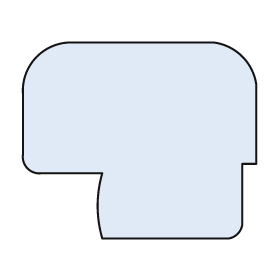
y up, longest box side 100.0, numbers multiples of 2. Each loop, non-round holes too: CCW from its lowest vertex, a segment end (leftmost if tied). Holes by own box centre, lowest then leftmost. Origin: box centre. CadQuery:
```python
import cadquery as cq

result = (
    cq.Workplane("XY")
    .moveTo(-16.0, -42.0)
    .lineTo(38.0, -42.0)
    .threePointArc((42.0, -40.0), (44.0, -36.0))
    .lineTo(44.0, -10.0)
    .lineTo(50.0, -10.0)
    .lineTo(50.0, 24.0)
    .threePointArc((44.0, 36.0), (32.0, 42.0))
    .lineTo(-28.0, 42.0)
    .threePointArc((-44.0, 36.0), (-50.0, 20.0))
    .lineTo(-50.0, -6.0)
    .threePointArc((-48.0, -12.0), (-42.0, -14.0))
    .lineTo(-16.0, -14.0)
    .threePointArc((-18.0, -28.0), (-16.0, -42.0))
    .close()
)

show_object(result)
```